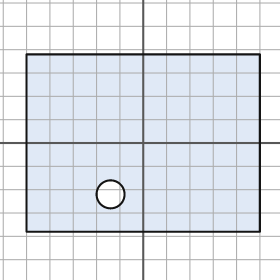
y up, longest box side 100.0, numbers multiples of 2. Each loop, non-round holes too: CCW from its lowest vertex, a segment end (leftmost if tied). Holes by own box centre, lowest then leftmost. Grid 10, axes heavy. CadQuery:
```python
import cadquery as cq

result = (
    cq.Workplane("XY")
    .moveTo(-50.0, -38.0)
    .lineTo(50.0, -38.0)
    .lineTo(50.0, 38.0)
    .lineTo(-50.0, 38.0)
    .close()
    .moveTo(-14.0, -22.0)
    .circle(6.0)
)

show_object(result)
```